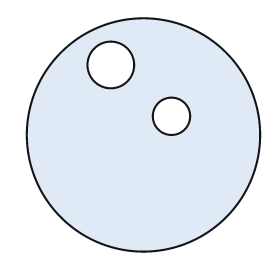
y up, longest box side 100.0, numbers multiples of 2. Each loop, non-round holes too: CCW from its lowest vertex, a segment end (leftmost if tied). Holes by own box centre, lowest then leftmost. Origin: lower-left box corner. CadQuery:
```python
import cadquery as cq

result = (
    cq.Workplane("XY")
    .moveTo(50.0, 50.0)
    .circle(50.0)
    .moveTo(62.0, 58.0)
    .circle(8.0)
    .moveTo(36.0, 80.0)
    .circle(10.0)
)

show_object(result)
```